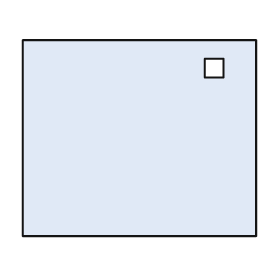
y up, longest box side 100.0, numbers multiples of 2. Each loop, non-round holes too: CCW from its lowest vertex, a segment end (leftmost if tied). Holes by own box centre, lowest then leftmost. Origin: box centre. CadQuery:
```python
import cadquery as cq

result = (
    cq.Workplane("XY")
    .moveTo(-50.0, -42.0)
    .lineTo(50.0, -42.0)
    .lineTo(50.0, 42.0)
    .lineTo(-50.0, 42.0)
    .close()
    .moveTo(28.0, 26.0)
    .lineTo(36.0, 26.0)
    .lineTo(36.0, 34.0)
    .lineTo(28.0, 34.0)
    .close()
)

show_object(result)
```